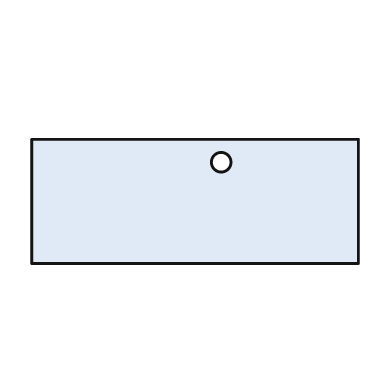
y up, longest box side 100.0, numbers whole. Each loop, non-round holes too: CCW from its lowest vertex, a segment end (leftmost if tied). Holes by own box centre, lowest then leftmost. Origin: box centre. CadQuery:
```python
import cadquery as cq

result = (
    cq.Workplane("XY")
    .moveTo(-50.0, -19.0)
    .lineTo(50.0, -19.0)
    .lineTo(50.0, 19.0)
    .lineTo(-50.0, 19.0)
    .close()
    .moveTo(8.0, 12.0)
    .circle(3.0)
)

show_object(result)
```